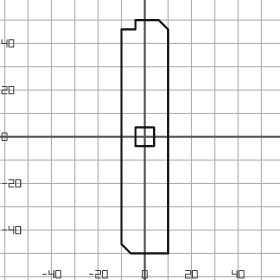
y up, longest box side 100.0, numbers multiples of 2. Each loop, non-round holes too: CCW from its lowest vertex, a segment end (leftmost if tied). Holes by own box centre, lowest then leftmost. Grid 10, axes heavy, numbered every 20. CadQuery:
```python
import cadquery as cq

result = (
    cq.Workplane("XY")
    .moveTo(-6.0, -50.0)
    .lineTo(10.0, -50.0)
    .lineTo(10.0, 46.0)
    .lineTo(6.0, 50.0)
    .lineTo(-4.0, 50.0)
    .lineTo(-4.0, 46.0)
    .lineTo(-10.0, 46.0)
    .lineTo(-10.0, -46.0)
    .close()
    .moveTo(-4.0, -4.0)
    .lineTo(4.0, -4.0)
    .lineTo(4.0, 4.0)
    .lineTo(-4.0, 4.0)
    .close()
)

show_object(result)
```